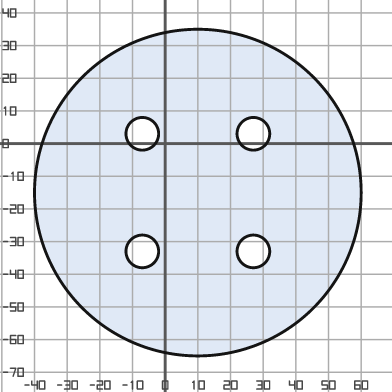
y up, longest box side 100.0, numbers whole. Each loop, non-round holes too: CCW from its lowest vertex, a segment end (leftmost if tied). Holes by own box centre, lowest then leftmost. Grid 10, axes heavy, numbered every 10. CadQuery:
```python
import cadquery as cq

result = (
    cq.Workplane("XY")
    .moveTo(10.0, -15.0)
    .circle(50.0)
    .moveTo(-7.0, -33.0)
    .circle(5.0)
    .moveTo(27.0, -33.0)
    .circle(5.0)
    .moveTo(-7.0, 3.0)
    .circle(5.0)
    .moveTo(27.0, 3.0)
    .circle(5.0)
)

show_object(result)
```